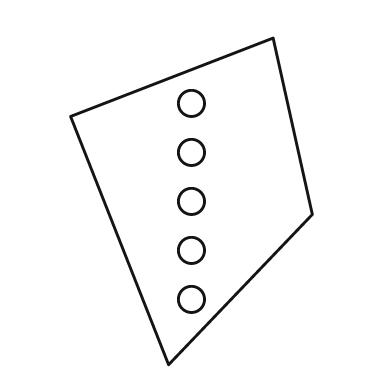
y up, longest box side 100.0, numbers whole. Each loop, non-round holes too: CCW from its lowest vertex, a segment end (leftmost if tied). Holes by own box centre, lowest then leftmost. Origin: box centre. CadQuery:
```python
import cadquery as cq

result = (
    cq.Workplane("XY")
    .moveTo(-7.0, -50.0)
    .lineTo(37.0, -4.0)
    .lineTo(25.0, 50.0)
    .lineTo(-37.0, 26.0)
    .close()
    .moveTo(0.0, -30.0)
    .circle(4.0)
    .moveTo(0.0, -15.0)
    .circle(4.0)
    .moveTo(0.0, 0.0)
    .circle(4.0)
    .moveTo(0.0, 15.0)
    .circle(4.0)
    .moveTo(0.0, 30.0)
    .circle(4.0)
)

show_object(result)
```